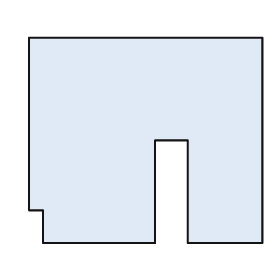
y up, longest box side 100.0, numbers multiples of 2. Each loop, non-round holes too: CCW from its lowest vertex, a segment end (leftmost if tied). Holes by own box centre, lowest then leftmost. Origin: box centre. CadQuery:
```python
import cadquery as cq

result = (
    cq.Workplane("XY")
    .moveTo(-44.0, -44.0)
    .lineTo(4.0, -44.0)
    .lineTo(4.0, 0.0)
    .lineTo(18.0, 0.0)
    .lineTo(18.0, -44.0)
    .lineTo(50.0, -44.0)
    .lineTo(50.0, 44.0)
    .lineTo(-50.0, 44.0)
    .lineTo(-50.0, -30.0)
    .lineTo(-44.0, -30.0)
    .close()
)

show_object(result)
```